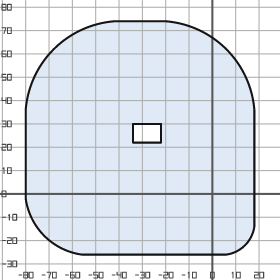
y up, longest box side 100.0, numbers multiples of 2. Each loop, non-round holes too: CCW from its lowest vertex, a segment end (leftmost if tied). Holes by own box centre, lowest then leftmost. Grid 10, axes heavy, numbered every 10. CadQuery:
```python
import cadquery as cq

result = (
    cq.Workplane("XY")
    .moveTo(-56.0, -26.0)
    .lineTo(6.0, -26.0)
    .threePointArc((14.0, -22.0), (18.0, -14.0))
    .lineTo(18.0, 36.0)
    .threePointArc((6.0, 62.0), (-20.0, 74.0))
    .lineTo(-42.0, 74.0)
    .threePointArc((-68.0, 62.0), (-80.0, 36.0))
    .lineTo(-80.0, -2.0)
    .threePointArc((-72.0, -18.0), (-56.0, -26.0))
    .close()
    .moveTo(-34.0, 22.0)
    .lineTo(-22.0, 22.0)
    .lineTo(-22.0, 30.0)
    .lineTo(-34.0, 30.0)
    .close()
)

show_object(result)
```